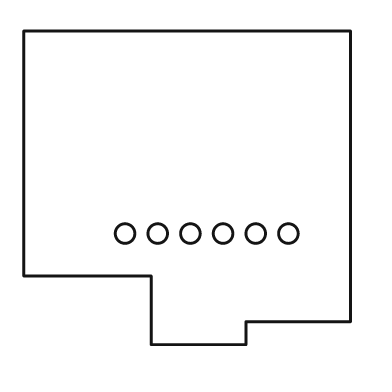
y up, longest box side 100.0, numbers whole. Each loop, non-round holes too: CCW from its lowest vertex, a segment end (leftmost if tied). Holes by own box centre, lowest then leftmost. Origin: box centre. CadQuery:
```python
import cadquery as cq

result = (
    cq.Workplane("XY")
    .moveTo(-11.0, -48.0)
    .lineTo(18.0, -48.0)
    .lineTo(18.0, -41.0)
    .lineTo(50.0, -41.0)
    .lineTo(50.0, 48.0)
    .lineTo(-50.0, 48.0)
    .lineTo(-50.0, -27.0)
    .lineTo(-11.0, -27.0)
    .close()
    .moveTo(-19.0, -14.0)
    .circle(3.0)
    .moveTo(-9.0, -14.0)
    .circle(3.0)
    .moveTo(1.0, -14.0)
    .circle(3.0)
    .moveTo(11.0, -14.0)
    .circle(3.0)
    .moveTo(21.0, -14.0)
    .circle(3.0)
    .moveTo(31.0, -14.0)
    .circle(3.0)
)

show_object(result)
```